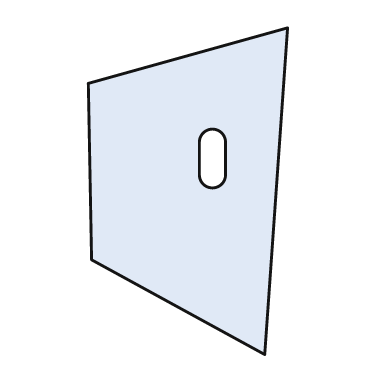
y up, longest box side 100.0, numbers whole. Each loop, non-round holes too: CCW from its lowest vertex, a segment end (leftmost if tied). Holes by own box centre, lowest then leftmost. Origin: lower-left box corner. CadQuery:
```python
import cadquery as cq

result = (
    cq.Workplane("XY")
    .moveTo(54.0, 0.0)
    .lineTo(61.0, 100.0)
    .lineTo(0.0, 83.0)
    .lineTo(1.0, 29.0)
    .close()
    .moveTo(34.0, 55.0)
    .threePointArc((38.0, 51.0), (42.0, 55.0))
    .lineTo(42.0, 65.0)
    .threePointArc((38.0, 69.0), (34.0, 65.0))
    .close()
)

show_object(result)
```